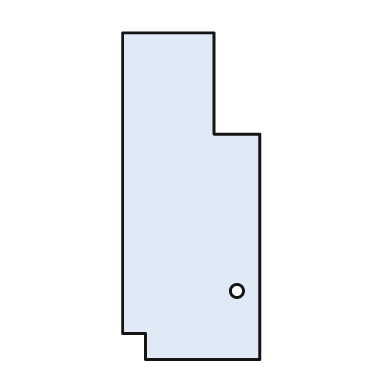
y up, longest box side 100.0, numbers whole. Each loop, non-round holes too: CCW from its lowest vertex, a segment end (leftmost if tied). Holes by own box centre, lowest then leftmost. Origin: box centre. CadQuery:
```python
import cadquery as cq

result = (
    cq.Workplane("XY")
    .moveTo(-14.0, -50.0)
    .lineTo(21.0, -50.0)
    .lineTo(21.0, 19.0)
    .lineTo(7.0, 19.0)
    .lineTo(7.0, 50.0)
    .lineTo(-21.0, 50.0)
    .lineTo(-21.0, -42.0)
    .lineTo(-14.0, -42.0)
    .close()
    .moveTo(14.0, -29.0)
    .circle(2.0)
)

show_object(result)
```